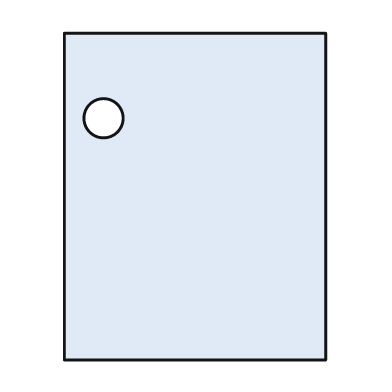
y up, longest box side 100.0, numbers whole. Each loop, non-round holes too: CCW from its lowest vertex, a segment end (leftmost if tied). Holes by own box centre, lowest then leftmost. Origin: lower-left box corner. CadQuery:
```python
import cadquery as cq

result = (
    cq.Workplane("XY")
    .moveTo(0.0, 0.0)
    .lineTo(80.0, 0.0)
    .lineTo(80.0, 100.0)
    .lineTo(0.0, 100.0)
    .close()
    .moveTo(12.0, 74.0)
    .circle(6.0)
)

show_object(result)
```